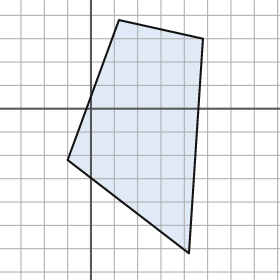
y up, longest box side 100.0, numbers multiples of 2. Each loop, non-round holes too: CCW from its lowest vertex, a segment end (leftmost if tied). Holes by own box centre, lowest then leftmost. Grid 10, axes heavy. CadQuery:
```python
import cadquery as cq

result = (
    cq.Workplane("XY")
    .moveTo(42.0, -62.0)
    .lineTo(48.0, 30.0)
    .lineTo(12.0, 38.0)
    .lineTo(-10.0, -22.0)
    .close()
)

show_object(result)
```